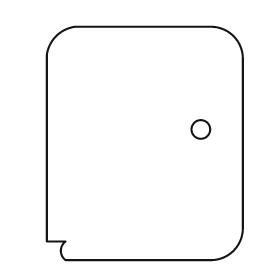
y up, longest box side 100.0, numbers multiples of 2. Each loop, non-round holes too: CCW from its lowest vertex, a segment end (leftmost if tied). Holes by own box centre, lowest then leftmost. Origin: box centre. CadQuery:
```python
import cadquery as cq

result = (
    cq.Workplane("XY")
    .moveTo(-34.0, -50.0)
    .lineTo(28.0, -50.0)
    .threePointArc((38.0, -46.0), (42.0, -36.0))
    .lineTo(42.0, 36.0)
    .threePointArc((38.0, 46.0), (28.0, 50.0))
    .lineTo(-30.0, 50.0)
    .threePointArc((-38.0, 46.0), (-42.0, 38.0))
    .lineTo(-42.0, -42.0)
    .lineTo(-34.0, -42.0)
    .threePointArc((-36.0, -46.0), (-34.0, -50.0))
    .close()
    .moveTo(24.0, 6.0)
    .circle(4.0)
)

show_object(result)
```